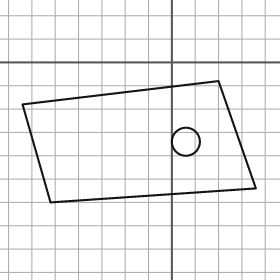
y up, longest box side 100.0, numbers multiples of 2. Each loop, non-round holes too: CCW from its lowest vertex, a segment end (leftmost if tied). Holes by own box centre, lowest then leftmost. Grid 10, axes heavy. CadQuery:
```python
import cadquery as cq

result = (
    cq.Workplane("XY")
    .moveTo(-52.0, -60.0)
    .lineTo(36.0, -54.0)
    .lineTo(20.0, -8.0)
    .lineTo(-64.0, -18.0)
    .close()
    .moveTo(6.0, -34.0)
    .circle(6.0)
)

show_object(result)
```